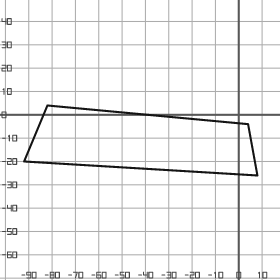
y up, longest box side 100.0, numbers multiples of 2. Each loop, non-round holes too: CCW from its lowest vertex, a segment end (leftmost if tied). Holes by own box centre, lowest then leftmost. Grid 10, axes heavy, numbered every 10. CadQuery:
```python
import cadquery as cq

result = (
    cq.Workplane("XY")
    .moveTo(8.0, -26.0)
    .lineTo(4.0, -4.0)
    .lineTo(-82.0, 4.0)
    .lineTo(-92.0, -20.0)
    .close()
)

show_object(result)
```